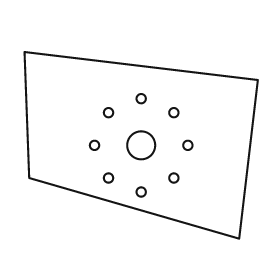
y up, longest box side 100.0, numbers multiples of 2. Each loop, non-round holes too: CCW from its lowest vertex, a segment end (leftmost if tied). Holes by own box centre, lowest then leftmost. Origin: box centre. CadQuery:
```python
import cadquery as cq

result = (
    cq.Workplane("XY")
    .moveTo(42.0, -40.0)
    .lineTo(50.0, 28.0)
    .lineTo(-50.0, 40.0)
    .lineTo(-48.0, -14.0)
    .close()
    .moveTo(0.0, -20.0)
    .circle(2.0)
    .moveTo(-14.0, -14.0)
    .circle(2.0)
    .moveTo(14.0, -14.0)
    .circle(2.0)
    .moveTo(-20.0, 0.0)
    .circle(2.0)
    .moveTo(0.0, 0.0)
    .circle(6.0)
    .moveTo(20.0, 0.0)
    .circle(2.0)
    .moveTo(-14.0, 14.0)
    .circle(2.0)
    .moveTo(14.0, 14.0)
    .circle(2.0)
    .moveTo(0.0, 20.0)
    .circle(2.0)
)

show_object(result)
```